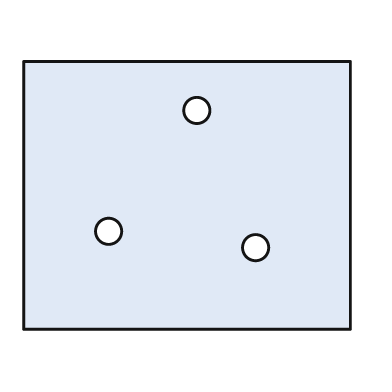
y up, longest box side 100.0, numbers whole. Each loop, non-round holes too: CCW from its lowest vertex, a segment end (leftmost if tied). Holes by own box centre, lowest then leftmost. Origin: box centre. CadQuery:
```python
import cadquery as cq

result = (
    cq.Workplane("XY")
    .moveTo(-50.0, -41.0)
    .lineTo(50.0, -41.0)
    .lineTo(50.0, 41.0)
    .lineTo(-50.0, 41.0)
    .close()
    .moveTo(21.0, -16.0)
    .circle(4.0)
    .moveTo(-24.0, -11.0)
    .circle(4.0)
    .moveTo(3.0, 26.0)
    .circle(4.0)
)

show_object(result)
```